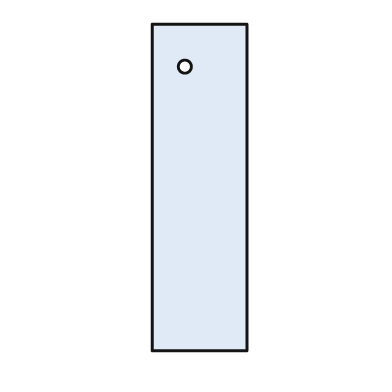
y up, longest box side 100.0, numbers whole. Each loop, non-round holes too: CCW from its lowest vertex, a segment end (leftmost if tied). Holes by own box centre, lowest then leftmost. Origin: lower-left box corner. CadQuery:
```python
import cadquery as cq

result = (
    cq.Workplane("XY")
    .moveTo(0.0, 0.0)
    .lineTo(29.0, 0.0)
    .lineTo(29.0, 100.0)
    .lineTo(0.0, 100.0)
    .close()
    .moveTo(10.0, 87.0)
    .circle(2.0)
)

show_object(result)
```